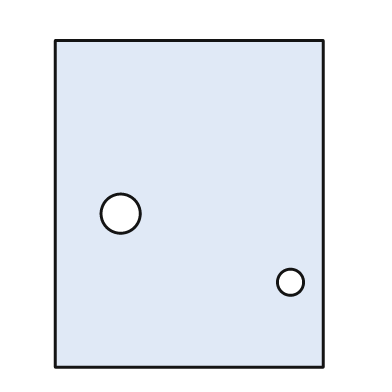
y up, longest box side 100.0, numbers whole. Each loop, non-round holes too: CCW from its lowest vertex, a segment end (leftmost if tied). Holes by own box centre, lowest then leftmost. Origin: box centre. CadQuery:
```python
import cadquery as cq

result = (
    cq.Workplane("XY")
    .moveTo(-41.0, -50.0)
    .lineTo(41.0, -50.0)
    .lineTo(41.0, 50.0)
    .lineTo(-41.0, 50.0)
    .close()
    .moveTo(31.0, -24.0)
    .circle(4.0)
    .moveTo(-21.0, -3.0)
    .circle(6.0)
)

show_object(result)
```